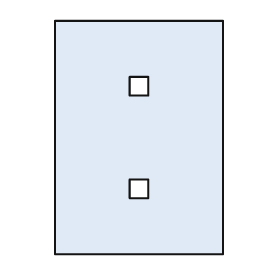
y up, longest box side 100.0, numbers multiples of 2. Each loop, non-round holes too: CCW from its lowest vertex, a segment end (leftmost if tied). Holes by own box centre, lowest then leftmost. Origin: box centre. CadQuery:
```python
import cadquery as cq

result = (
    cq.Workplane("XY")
    .moveTo(-36.0, -50.0)
    .lineTo(36.0, -50.0)
    .lineTo(36.0, 50.0)
    .lineTo(-36.0, 50.0)
    .close()
    .moveTo(-4.0, -26.0)
    .lineTo(4.0, -26.0)
    .lineTo(4.0, -18.0)
    .lineTo(-4.0, -18.0)
    .close()
    .moveTo(-4.0, 18.0)
    .lineTo(4.0, 18.0)
    .lineTo(4.0, 26.0)
    .lineTo(-4.0, 26.0)
    .close()
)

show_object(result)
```